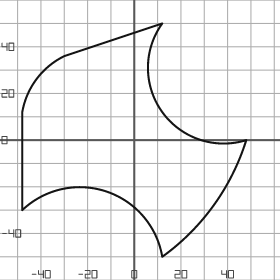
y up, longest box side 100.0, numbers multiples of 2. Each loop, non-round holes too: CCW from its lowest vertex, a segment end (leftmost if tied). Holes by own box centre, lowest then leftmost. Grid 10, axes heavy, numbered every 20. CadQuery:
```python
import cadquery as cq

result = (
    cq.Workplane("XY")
    .moveTo(12.0, -50.0)
    .threePointArc((34.0, -28.0), (48.0, 0.0))
    .threePointArc((12.0, 12.0), (12.0, 50.0))
    .lineTo(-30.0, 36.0)
    .threePointArc((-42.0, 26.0), (-48.0, 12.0))
    .lineTo(-48.0, -30.0)
    .threePointArc((-12.0, -22.0), (12.0, -50.0))
    .close()
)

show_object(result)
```